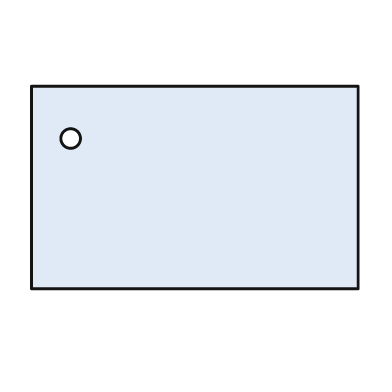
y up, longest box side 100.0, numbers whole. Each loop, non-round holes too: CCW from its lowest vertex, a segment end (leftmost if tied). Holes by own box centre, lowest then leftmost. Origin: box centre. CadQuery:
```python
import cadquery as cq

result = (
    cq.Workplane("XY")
    .moveTo(-50.0, -31.0)
    .lineTo(50.0, -31.0)
    .lineTo(50.0, 31.0)
    .lineTo(-50.0, 31.0)
    .close()
    .moveTo(-38.0, 15.0)
    .circle(3.0)
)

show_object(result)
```